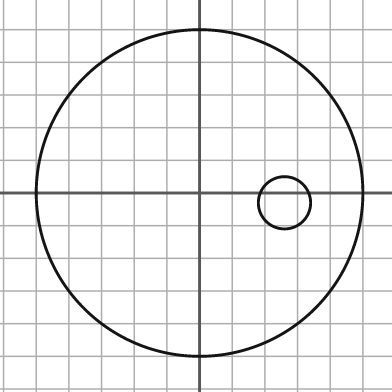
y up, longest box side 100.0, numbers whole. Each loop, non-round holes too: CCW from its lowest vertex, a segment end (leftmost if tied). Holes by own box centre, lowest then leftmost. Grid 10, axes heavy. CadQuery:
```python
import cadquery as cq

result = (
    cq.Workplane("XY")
    .moveTo(0.0, 0.0)
    .circle(50.0)
    .moveTo(26.0, -3.0)
    .circle(8.0)
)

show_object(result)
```